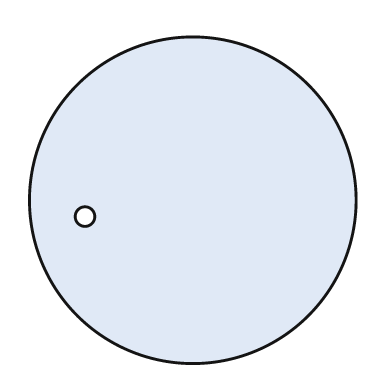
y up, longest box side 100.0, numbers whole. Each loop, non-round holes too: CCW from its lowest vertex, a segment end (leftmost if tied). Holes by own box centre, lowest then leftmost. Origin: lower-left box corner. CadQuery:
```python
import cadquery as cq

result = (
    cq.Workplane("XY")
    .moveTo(50.0, 50.0)
    .circle(50.0)
    .moveTo(17.0, 45.0)
    .circle(3.0)
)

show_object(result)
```